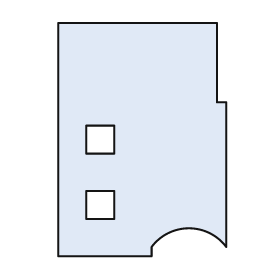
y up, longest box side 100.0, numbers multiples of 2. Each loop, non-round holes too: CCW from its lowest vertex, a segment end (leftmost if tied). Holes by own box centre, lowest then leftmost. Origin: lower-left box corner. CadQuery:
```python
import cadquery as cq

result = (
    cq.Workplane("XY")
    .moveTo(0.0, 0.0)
    .lineTo(40.0, 0.0)
    .lineTo(40.0, 4.0)
    .threePointArc((56.0, 12.0), (72.0, 4.0))
    .lineTo(72.0, 66.0)
    .lineTo(68.0, 66.0)
    .lineTo(68.0, 100.0)
    .lineTo(0.0, 100.0)
    .close()
    .moveTo(12.0, 16.0)
    .lineTo(24.0, 16.0)
    .lineTo(24.0, 28.0)
    .lineTo(12.0, 28.0)
    .close()
    .moveTo(12.0, 44.0)
    .lineTo(24.0, 44.0)
    .lineTo(24.0, 56.0)
    .lineTo(12.0, 56.0)
    .close()
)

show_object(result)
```